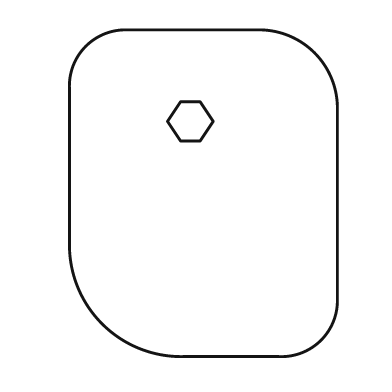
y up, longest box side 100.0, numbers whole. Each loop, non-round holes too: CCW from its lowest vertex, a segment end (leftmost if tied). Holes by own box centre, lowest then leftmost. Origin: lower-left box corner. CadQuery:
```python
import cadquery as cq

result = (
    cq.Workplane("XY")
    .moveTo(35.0, 0.0)
    .lineTo(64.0, 0.0)
    .threePointArc((77.0, 5.0), (82.0, 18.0))
    .lineTo(82.0, 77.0)
    .threePointArc((75.0, 93.0), (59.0, 100.0))
    .lineTo(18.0, 100.0)
    .threePointArc((5.0, 95.0), (0.0, 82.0))
    .lineTo(0.0, 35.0)
    .threePointArc((10.0, 10.0), (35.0, 0.0))
    .close()
    .moveTo(34.0, 66.0)
    .lineTo(40.0, 66.0)
    .lineTo(44.0, 72.0)
    .lineTo(40.0, 78.0)
    .lineTo(34.0, 78.0)
    .lineTo(30.0, 72.0)
    .close()
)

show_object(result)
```